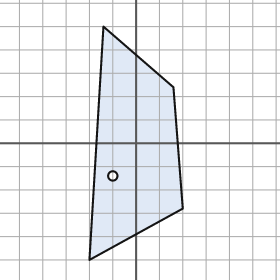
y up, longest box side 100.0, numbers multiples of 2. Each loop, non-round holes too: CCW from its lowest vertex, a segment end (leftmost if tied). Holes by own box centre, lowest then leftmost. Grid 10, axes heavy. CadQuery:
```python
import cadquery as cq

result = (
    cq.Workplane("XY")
    .moveTo(-20.0, -50.0)
    .lineTo(20.0, -28.0)
    .lineTo(16.0, 24.0)
    .lineTo(-14.0, 50.0)
    .close()
    .moveTo(-10.0, -14.0)
    .circle(2.0)
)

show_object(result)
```